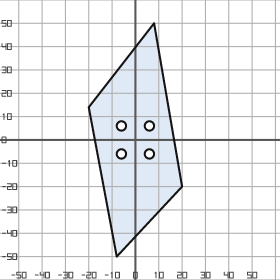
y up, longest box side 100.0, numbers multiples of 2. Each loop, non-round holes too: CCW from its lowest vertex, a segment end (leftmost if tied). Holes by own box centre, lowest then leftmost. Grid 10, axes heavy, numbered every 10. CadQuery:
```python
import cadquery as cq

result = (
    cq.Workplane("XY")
    .moveTo(-8.0, -50.0)
    .lineTo(20.0, -20.0)
    .lineTo(8.0, 50.0)
    .lineTo(-20.0, 14.0)
    .close()
    .moveTo(-6.0, -6.0)
    .circle(2.0)
    .moveTo(6.0, -6.0)
    .circle(2.0)
    .moveTo(-6.0, 6.0)
    .circle(2.0)
    .moveTo(6.0, 6.0)
    .circle(2.0)
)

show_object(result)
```